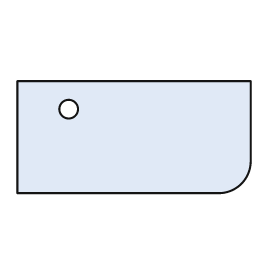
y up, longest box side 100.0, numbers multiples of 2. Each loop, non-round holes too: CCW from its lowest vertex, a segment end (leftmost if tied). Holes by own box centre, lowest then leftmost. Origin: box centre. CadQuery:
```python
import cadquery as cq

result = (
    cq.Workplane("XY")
    .moveTo(-50.0, -24.0)
    .lineTo(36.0, -24.0)
    .threePointArc((46.0, -20.0), (50.0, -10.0))
    .lineTo(50.0, 24.0)
    .lineTo(-50.0, 24.0)
    .close()
    .moveTo(-28.0, 12.0)
    .circle(4.0)
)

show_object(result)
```